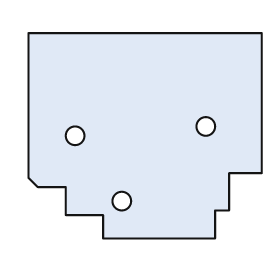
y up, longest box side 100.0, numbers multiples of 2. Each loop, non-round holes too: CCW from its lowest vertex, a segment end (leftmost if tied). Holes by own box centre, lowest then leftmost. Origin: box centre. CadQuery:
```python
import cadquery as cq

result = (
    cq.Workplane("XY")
    .moveTo(-18.0, -44.0)
    .lineTo(30.0, -44.0)
    .lineTo(30.0, -32.0)
    .lineTo(36.0, -32.0)
    .lineTo(36.0, -16.0)
    .lineTo(50.0, -16.0)
    .lineTo(50.0, 44.0)
    .lineTo(-50.0, 44.0)
    .lineTo(-50.0, -18.0)
    .lineTo(-46.0, -22.0)
    .lineTo(-34.0, -22.0)
    .lineTo(-34.0, -34.0)
    .lineTo(-18.0, -34.0)
    .close()
    .moveTo(-10.0, -28.0)
    .circle(4.0)
    .moveTo(-30.0, 0.0)
    .circle(4.0)
    .moveTo(26.0, 4.0)
    .circle(4.0)
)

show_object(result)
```